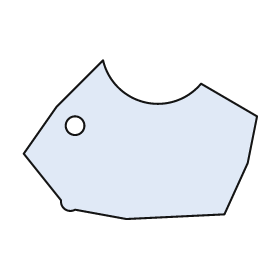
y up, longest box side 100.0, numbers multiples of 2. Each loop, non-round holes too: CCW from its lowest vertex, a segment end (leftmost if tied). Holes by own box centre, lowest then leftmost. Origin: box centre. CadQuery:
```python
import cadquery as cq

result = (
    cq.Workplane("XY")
    .moveTo(-6.0, -34.0)
    .lineTo(36.0, -32.0)
    .lineTo(46.0, -10.0)
    .lineTo(50.0, 10.0)
    .lineTo(26.0, 24.0)
    .threePointArc((2.0, 16.0), (-16.0, 34.0))
    .lineTo(-36.0, 14.0)
    .lineTo(-50.0, -6.0)
    .lineTo(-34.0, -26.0)
    .threePointArc((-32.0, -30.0), (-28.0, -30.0))
    .close()
    .moveTo(-28.0, 6.0)
    .circle(4.0)
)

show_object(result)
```